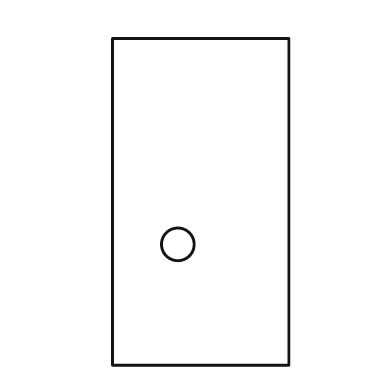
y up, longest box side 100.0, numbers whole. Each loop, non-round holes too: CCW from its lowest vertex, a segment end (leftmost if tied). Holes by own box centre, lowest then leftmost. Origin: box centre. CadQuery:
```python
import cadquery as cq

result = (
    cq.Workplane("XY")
    .moveTo(-27.0, -50.0)
    .lineTo(27.0, -50.0)
    .lineTo(27.0, 50.0)
    .lineTo(-27.0, 50.0)
    .close()
    .moveTo(-7.0, -13.0)
    .circle(5.0)
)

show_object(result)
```